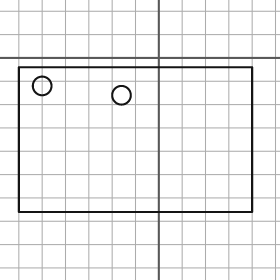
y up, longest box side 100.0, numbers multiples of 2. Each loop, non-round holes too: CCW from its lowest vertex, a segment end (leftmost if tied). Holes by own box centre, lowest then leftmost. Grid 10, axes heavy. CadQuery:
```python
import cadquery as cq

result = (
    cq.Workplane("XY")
    .moveTo(-60.0, -66.0)
    .lineTo(40.0, -66.0)
    .lineTo(40.0, -4.0)
    .lineTo(-60.0, -4.0)
    .close()
    .moveTo(-16.0, -16.0)
    .circle(4.0)
    .moveTo(-50.0, -12.0)
    .circle(4.0)
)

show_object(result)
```